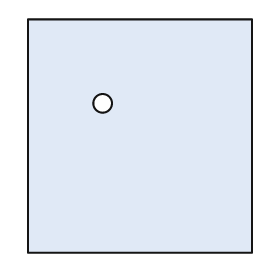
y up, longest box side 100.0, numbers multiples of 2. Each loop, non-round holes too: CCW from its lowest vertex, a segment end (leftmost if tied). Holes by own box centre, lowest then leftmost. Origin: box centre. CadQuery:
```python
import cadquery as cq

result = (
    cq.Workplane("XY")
    .moveTo(-48.0, -50.0)
    .lineTo(48.0, -50.0)
    .lineTo(48.0, 50.0)
    .lineTo(-48.0, 50.0)
    .close()
    .moveTo(-16.0, 14.0)
    .circle(4.0)
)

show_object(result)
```